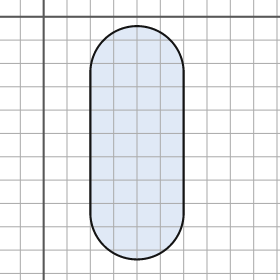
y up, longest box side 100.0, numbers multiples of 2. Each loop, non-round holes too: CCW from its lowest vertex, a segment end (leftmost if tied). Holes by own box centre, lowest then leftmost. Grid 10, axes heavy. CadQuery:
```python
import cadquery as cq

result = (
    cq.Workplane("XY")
    .moveTo(20.0, -84.0)
    .threePointArc((40.0, -104.0), (60.0, -84.0))
    .lineTo(60.0, -24.0)
    .threePointArc((40.0, -4.0), (20.0, -24.0))
    .close()
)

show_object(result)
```